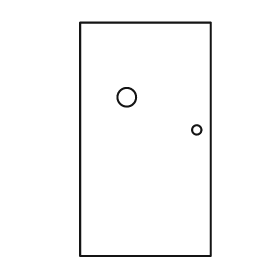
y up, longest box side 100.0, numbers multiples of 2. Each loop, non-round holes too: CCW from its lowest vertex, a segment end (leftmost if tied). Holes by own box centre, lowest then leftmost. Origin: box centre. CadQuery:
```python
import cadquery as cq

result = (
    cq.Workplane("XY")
    .moveTo(-28.0, -50.0)
    .lineTo(28.0, -50.0)
    .lineTo(28.0, 50.0)
    .lineTo(-28.0, 50.0)
    .close()
    .moveTo(22.0, 4.0)
    .circle(2.0)
    .moveTo(-8.0, 18.0)
    .circle(4.0)
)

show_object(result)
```